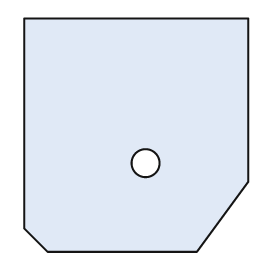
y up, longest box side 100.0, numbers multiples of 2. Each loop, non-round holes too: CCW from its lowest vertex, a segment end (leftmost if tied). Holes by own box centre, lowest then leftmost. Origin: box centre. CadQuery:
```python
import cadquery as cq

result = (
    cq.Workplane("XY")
    .moveTo(-38.0, -50.0)
    .lineTo(26.0, -50.0)
    .lineTo(48.0, -20.0)
    .lineTo(48.0, 50.0)
    .lineTo(-48.0, 50.0)
    .lineTo(-48.0, -40.0)
    .close()
    .moveTo(4.0, -12.0)
    .circle(6.0)
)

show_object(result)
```